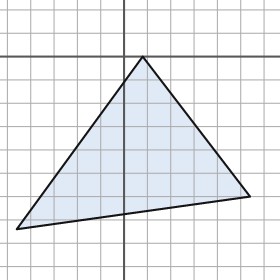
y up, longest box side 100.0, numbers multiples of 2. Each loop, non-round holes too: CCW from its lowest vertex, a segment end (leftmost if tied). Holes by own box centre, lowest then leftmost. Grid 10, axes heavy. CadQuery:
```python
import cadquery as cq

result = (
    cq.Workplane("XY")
    .moveTo(-46.0, -74.0)
    .lineTo(54.0, -60.0)
    .lineTo(8.0, 0.0)
    .close()
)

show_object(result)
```